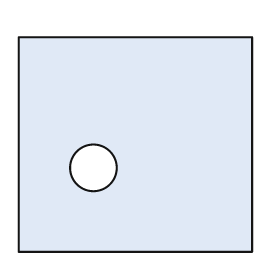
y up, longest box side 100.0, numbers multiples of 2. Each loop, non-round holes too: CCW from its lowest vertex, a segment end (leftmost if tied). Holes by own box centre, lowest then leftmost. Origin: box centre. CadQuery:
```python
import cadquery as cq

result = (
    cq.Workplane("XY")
    .moveTo(-50.0, -46.0)
    .lineTo(50.0, -46.0)
    .lineTo(50.0, 46.0)
    .lineTo(-50.0, 46.0)
    .close()
    .moveTo(-18.0, -10.0)
    .circle(10.0)
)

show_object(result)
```